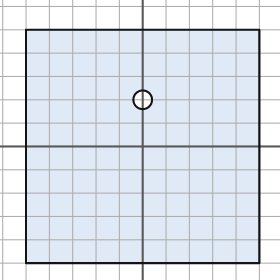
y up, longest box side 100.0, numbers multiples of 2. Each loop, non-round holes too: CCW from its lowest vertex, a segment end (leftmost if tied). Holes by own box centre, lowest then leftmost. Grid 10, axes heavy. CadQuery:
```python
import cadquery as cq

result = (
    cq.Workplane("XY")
    .moveTo(-50.0, -50.0)
    .lineTo(50.0, -50.0)
    .lineTo(50.0, 50.0)
    .lineTo(-50.0, 50.0)
    .close()
    .moveTo(0.0, 20.0)
    .circle(4.0)
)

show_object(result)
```